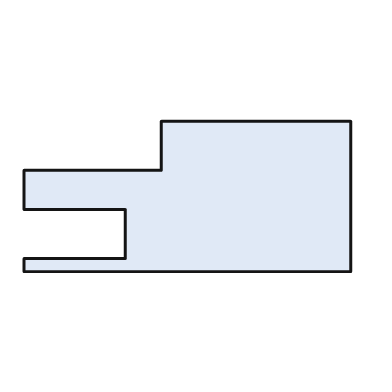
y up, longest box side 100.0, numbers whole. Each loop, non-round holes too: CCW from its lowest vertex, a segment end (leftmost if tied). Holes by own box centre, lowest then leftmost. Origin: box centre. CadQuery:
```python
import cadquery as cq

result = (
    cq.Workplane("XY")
    .moveTo(-50.0, -23.0)
    .lineTo(50.0, -23.0)
    .lineTo(50.0, 23.0)
    .lineTo(-8.0, 23.0)
    .lineTo(-8.0, 8.0)
    .lineTo(-50.0, 8.0)
    .lineTo(-50.0, -4.0)
    .lineTo(-19.0, -4.0)
    .lineTo(-19.0, -19.0)
    .lineTo(-50.0, -19.0)
    .close()
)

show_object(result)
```